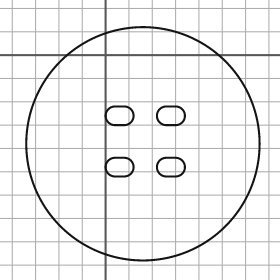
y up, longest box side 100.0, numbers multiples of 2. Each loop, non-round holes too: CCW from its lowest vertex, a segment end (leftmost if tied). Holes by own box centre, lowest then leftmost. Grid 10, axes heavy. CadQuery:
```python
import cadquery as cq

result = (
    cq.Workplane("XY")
    .moveTo(16.0, -38.0)
    .circle(50.0)
    .moveTo(4.0, -52.0)
    .lineTo(8.0, -52.0)
    .threePointArc((12.0, -48.0), (8.0, -44.0))
    .lineTo(4.0, -44.0)
    .threePointArc((0.0, -48.0), (4.0, -52.0))
    .close()
    .moveTo(26.0, -52.0)
    .lineTo(30.0, -52.0)
    .threePointArc((34.0, -48.0), (30.0, -44.0))
    .lineTo(26.0, -44.0)
    .threePointArc((22.0, -48.0), (26.0, -52.0))
    .close()
    .moveTo(4.0, -30.0)
    .lineTo(8.0, -30.0)
    .threePointArc((12.0, -26.0), (8.0, -22.0))
    .lineTo(4.0, -22.0)
    .threePointArc((0.0, -26.0), (4.0, -30.0))
    .close()
    .moveTo(26.0, -30.0)
    .lineTo(30.0, -30.0)
    .threePointArc((34.0, -26.0), (30.0, -22.0))
    .lineTo(26.0, -22.0)
    .threePointArc((22.0, -26.0), (26.0, -30.0))
    .close()
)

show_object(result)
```